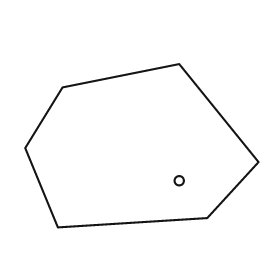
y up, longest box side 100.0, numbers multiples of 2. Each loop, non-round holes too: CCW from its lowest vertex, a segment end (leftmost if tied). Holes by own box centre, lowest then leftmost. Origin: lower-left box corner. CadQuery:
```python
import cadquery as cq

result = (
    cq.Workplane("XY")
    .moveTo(14.0, 0.0)
    .lineTo(78.0, 4.0)
    .lineTo(100.0, 28.0)
    .lineTo(66.0, 70.0)
    .lineTo(16.0, 60.0)
    .lineTo(0.0, 34.0)
    .close()
    .moveTo(66.0, 20.0)
    .circle(2.0)
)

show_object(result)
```